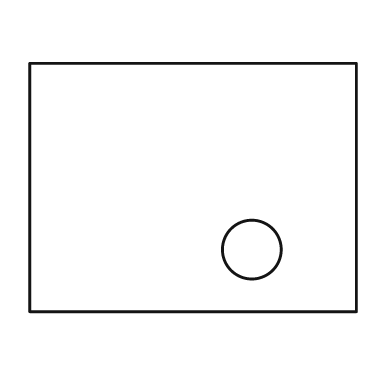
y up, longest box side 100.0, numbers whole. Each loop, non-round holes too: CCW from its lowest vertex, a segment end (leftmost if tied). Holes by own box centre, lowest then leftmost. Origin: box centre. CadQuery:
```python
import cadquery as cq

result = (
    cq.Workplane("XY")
    .moveTo(-50.0, -38.0)
    .lineTo(50.0, -38.0)
    .lineTo(50.0, 38.0)
    .lineTo(-50.0, 38.0)
    .close()
    .moveTo(18.0, -19.0)
    .circle(9.0)
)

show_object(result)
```